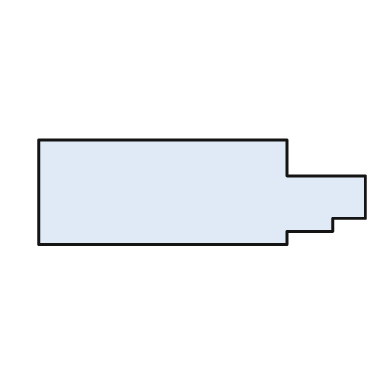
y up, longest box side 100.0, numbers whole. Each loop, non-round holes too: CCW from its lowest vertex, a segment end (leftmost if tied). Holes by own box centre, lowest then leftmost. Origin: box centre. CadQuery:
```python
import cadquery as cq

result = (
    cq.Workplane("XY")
    .moveTo(-50.0, -16.0)
    .lineTo(26.0, -16.0)
    .lineTo(26.0, -12.0)
    .lineTo(40.0, -12.0)
    .lineTo(40.0, -8.0)
    .lineTo(50.0, -8.0)
    .lineTo(50.0, 5.0)
    .lineTo(26.0, 5.0)
    .lineTo(26.0, 16.0)
    .lineTo(-50.0, 16.0)
    .close()
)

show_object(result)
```